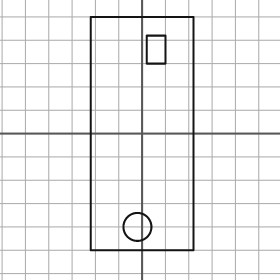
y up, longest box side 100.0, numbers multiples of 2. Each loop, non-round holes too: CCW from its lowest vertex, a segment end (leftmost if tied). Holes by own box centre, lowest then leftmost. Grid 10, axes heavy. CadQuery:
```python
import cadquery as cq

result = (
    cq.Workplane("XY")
    .moveTo(-22.0, -50.0)
    .lineTo(22.0, -50.0)
    .lineTo(22.0, 50.0)
    .lineTo(-22.0, 50.0)
    .close()
    .moveTo(-2.0, -40.0)
    .circle(6.0)
    .moveTo(2.0, 30.0)
    .lineTo(10.0, 30.0)
    .lineTo(10.0, 42.0)
    .lineTo(2.0, 42.0)
    .close()
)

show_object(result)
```